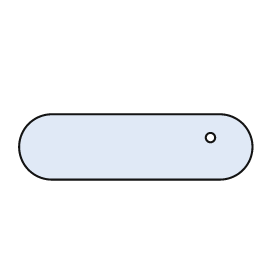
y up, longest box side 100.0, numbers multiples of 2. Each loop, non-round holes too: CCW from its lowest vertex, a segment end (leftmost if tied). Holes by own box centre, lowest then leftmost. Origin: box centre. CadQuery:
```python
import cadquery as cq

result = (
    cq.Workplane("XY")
    .moveTo(-36.0, -14.0)
    .lineTo(36.0, -14.0)
    .threePointArc((50.0, 0.0), (36.0, 14.0))
    .lineTo(-36.0, 14.0)
    .threePointArc((-50.0, 0.0), (-36.0, -14.0))
    .close()
    .moveTo(32.0, 4.0)
    .circle(2.0)
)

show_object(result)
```